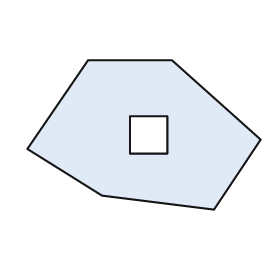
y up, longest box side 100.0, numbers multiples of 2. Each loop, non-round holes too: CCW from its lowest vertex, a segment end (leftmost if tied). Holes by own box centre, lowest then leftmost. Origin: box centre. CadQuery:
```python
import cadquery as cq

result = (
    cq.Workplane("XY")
    .moveTo(30.0, -32.0)
    .lineTo(50.0, -2.0)
    .lineTo(12.0, 32.0)
    .lineTo(-24.0, 32.0)
    .lineTo(-50.0, -6.0)
    .lineTo(-18.0, -26.0)
    .close()
    .moveTo(-6.0, -8.0)
    .lineTo(10.0, -8.0)
    .lineTo(10.0, 8.0)
    .lineTo(-6.0, 8.0)
    .close()
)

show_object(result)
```